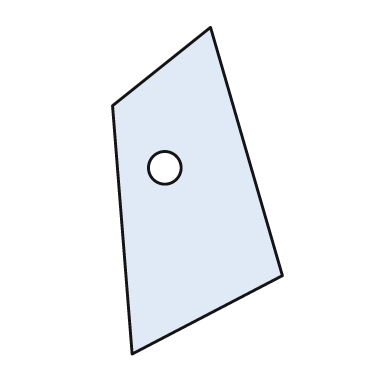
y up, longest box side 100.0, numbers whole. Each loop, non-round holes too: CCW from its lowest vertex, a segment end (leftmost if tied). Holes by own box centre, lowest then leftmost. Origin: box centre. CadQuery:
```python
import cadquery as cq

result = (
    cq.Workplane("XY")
    .moveTo(-20.0, -50.0)
    .lineTo(26.0, -26.0)
    .lineTo(4.0, 50.0)
    .lineTo(-26.0, 26.0)
    .close()
    .moveTo(-10.0, 7.0)
    .circle(5.0)
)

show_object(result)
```